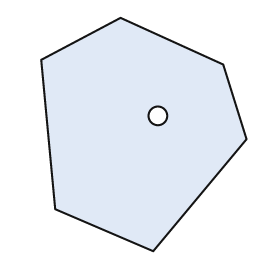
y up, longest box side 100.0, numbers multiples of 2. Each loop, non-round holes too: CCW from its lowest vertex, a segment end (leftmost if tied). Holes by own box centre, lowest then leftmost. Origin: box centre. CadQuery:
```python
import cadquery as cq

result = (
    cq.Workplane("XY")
    .moveTo(4.0, -50.0)
    .lineTo(44.0, -2.0)
    .lineTo(34.0, 30.0)
    .lineTo(-10.0, 50.0)
    .lineTo(-44.0, 32.0)
    .lineTo(-38.0, -32.0)
    .close()
    .moveTo(6.0, 8.0)
    .circle(4.0)
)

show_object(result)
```